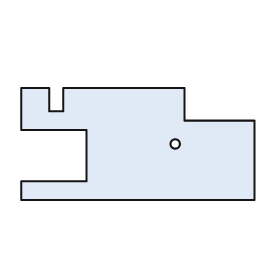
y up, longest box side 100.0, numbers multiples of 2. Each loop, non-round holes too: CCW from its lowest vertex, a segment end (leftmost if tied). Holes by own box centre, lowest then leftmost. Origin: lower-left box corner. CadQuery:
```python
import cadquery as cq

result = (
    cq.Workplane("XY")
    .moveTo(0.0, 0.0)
    .lineTo(100.0, 0.0)
    .lineTo(100.0, 34.0)
    .lineTo(70.0, 34.0)
    .lineTo(70.0, 48.0)
    .lineTo(18.0, 48.0)
    .lineTo(18.0, 38.0)
    .lineTo(12.0, 38.0)
    .lineTo(12.0, 48.0)
    .lineTo(0.0, 48.0)
    .lineTo(0.0, 30.0)
    .lineTo(28.0, 30.0)
    .lineTo(28.0, 8.0)
    .lineTo(0.0, 8.0)
    .close()
    .moveTo(66.0, 24.0)
    .circle(2.0)
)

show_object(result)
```